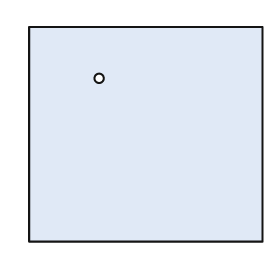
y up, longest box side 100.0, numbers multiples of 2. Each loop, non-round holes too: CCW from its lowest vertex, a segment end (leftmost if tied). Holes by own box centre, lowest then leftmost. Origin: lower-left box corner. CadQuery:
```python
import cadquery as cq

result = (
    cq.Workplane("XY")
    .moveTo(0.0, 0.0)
    .lineTo(100.0, 0.0)
    .lineTo(100.0, 92.0)
    .lineTo(0.0, 92.0)
    .close()
    .moveTo(30.0, 70.0)
    .circle(2.0)
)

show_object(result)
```